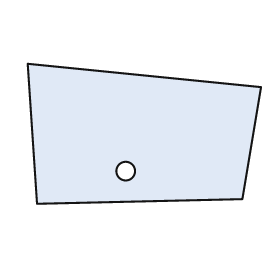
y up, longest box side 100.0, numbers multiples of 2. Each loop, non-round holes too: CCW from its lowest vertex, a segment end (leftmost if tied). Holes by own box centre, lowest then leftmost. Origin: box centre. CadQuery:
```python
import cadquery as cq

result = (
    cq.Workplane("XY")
    .moveTo(-46.0, -30.0)
    .lineTo(42.0, -28.0)
    .lineTo(50.0, 20.0)
    .lineTo(-50.0, 30.0)
    .close()
    .moveTo(-8.0, -16.0)
    .circle(4.0)
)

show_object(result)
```